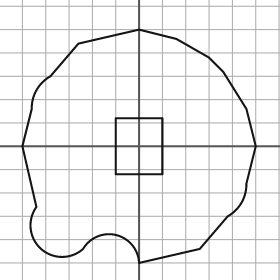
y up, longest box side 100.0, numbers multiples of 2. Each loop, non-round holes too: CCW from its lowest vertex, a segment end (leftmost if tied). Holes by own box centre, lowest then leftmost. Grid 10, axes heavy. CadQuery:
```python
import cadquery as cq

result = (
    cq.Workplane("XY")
    .moveTo(0.0, -50.0)
    .lineTo(26.0, -44.0)
    .lineTo(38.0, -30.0)
    .threePointArc((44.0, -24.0), (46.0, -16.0))
    .lineTo(50.0, 0.0)
    .lineTo(46.0, 16.0)
    .lineTo(36.0, 32.0)
    .lineTo(30.0, 38.0)
    .lineTo(16.0, 46.0)
    .lineTo(0.0, 50.0)
    .lineTo(-26.0, 44.0)
    .lineTo(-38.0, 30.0)
    .threePointArc((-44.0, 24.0), (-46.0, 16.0))
    .lineTo(-50.0, 0.0)
    .lineTo(-44.0, -26.0)
    .threePointArc((-42.0, -44.0), (-24.0, -44.0))
    .threePointArc((-10.0, -38.0), (0.0, -50.0))
    .close()
    .moveTo(-10.0, -12.0)
    .lineTo(10.0, -12.0)
    .lineTo(10.0, 12.0)
    .lineTo(-10.0, 12.0)
    .close()
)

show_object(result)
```